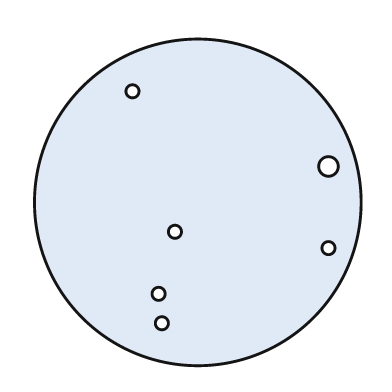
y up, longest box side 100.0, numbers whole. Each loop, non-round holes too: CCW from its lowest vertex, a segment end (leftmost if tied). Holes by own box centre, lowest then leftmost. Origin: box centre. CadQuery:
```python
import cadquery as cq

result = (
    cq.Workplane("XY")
    .moveTo(0.0, 0.0)
    .circle(50.0)
    .moveTo(-11.0, -37.0)
    .circle(2.0)
    .moveTo(-12.0, -28.0)
    .circle(2.0)
    .moveTo(40.0, -14.0)
    .circle(2.0)
    .moveTo(-7.0, -9.0)
    .circle(2.0)
    .moveTo(40.0, 11.0)
    .circle(3.0)
    .moveTo(-20.0, 34.0)
    .circle(2.0)
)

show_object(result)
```